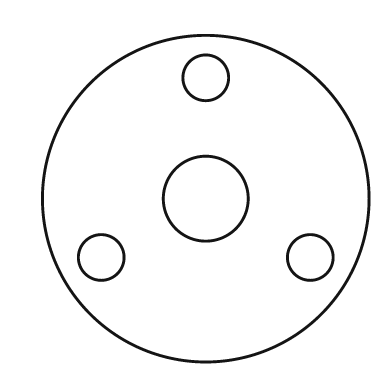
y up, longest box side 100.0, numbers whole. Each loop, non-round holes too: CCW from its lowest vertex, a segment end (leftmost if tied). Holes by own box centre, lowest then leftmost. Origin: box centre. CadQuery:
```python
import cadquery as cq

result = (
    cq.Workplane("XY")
    .moveTo(0.0, 0.0)
    .circle(50.0)
    .moveTo(-32.0, -18.0)
    .circle(7.0)
    .moveTo(32.0, -18.0)
    .circle(7.0)
    .moveTo(0.0, 0.0)
    .circle(13.0)
    .moveTo(0.0, 37.0)
    .circle(7.0)
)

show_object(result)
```